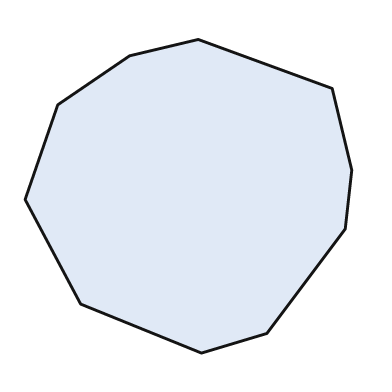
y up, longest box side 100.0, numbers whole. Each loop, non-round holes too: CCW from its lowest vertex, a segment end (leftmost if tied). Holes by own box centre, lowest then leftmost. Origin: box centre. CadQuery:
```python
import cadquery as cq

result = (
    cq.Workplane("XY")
    .moveTo(4.0, -48.0)
    .lineTo(24.0, -42.0)
    .lineTo(48.0, -10.0)
    .lineTo(50.0, 8.0)
    .lineTo(44.0, 33.0)
    .lineTo(3.0, 48.0)
    .lineTo(-18.0, 43.0)
    .lineTo(-40.0, 28.0)
    .lineTo(-50.0, -1.0)
    .lineTo(-33.0, -33.0)
    .close()
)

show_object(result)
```